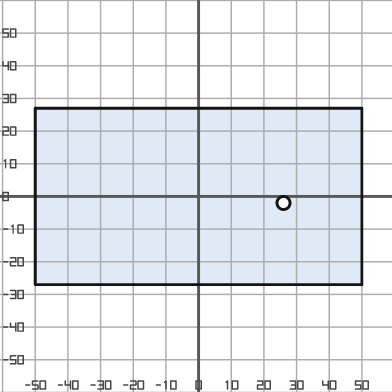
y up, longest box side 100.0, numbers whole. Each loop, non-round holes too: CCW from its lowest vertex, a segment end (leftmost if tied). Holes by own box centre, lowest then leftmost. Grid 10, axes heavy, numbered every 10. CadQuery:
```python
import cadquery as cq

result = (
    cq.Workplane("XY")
    .moveTo(-50.0, -27.0)
    .lineTo(50.0, -27.0)
    .lineTo(50.0, 27.0)
    .lineTo(-50.0, 27.0)
    .close()
    .moveTo(26.0, -2.0)
    .circle(2.0)
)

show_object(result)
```